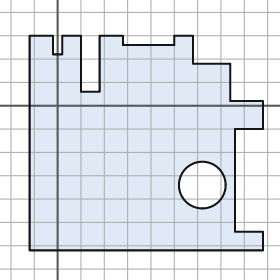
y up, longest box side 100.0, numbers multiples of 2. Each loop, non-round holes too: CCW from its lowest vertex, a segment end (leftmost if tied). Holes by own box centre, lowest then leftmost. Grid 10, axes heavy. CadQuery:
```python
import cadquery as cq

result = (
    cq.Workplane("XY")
    .moveTo(-12.0, -62.0)
    .lineTo(88.0, -62.0)
    .lineTo(88.0, -54.0)
    .lineTo(76.0, -54.0)
    .lineTo(76.0, -10.0)
    .lineTo(88.0, -10.0)
    .lineTo(88.0, 2.0)
    .lineTo(74.0, 2.0)
    .lineTo(74.0, 18.0)
    .lineTo(58.0, 18.0)
    .lineTo(58.0, 30.0)
    .lineTo(50.0, 30.0)
    .lineTo(50.0, 26.0)
    .lineTo(28.0, 26.0)
    .lineTo(28.0, 30.0)
    .lineTo(18.0, 30.0)
    .lineTo(18.0, 6.0)
    .lineTo(10.0, 6.0)
    .lineTo(10.0, 30.0)
    .lineTo(2.0, 30.0)
    .lineTo(2.0, 22.0)
    .lineTo(-2.0, 22.0)
    .lineTo(-2.0, 30.0)
    .lineTo(-12.0, 30.0)
    .close()
    .moveTo(62.0, -34.0)
    .circle(10.0)
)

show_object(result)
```